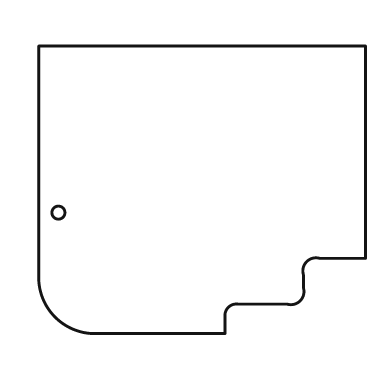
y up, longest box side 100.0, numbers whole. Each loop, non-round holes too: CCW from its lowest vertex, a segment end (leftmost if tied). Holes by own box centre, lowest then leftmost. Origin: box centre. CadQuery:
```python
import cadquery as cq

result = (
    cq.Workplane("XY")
    .moveTo(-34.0, -44.0)
    .lineTo(7.0, -44.0)
    .lineTo(7.0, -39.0)
    .threePointArc((8.0, -36.0), (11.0, -35.0))
    .lineTo(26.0, -35.0)
    .threePointArc((30.0, -34.0), (31.0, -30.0))
    .lineTo(31.0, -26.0)
    .threePointArc((32.0, -22.0), (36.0, -21.0))
    .lineTo(50.0, -21.0)
    .lineTo(50.0, 44.0)
    .lineTo(-50.0, 44.0)
    .lineTo(-50.0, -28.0)
    .threePointArc((-45.0, -39.0), (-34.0, -44.0))
    .close()
    .moveTo(-44.0, -7.0)
    .circle(2.0)
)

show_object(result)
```